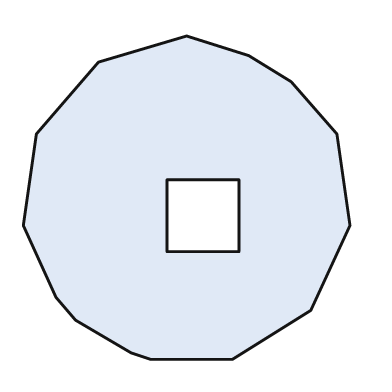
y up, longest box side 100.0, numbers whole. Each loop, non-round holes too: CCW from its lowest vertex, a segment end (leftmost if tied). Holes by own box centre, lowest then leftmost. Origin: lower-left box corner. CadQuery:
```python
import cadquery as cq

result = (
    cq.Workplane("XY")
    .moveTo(39.0, 0.0)
    .lineTo(64.0, 0.0)
    .lineTo(88.0, 15.0)
    .lineTo(100.0, 41.0)
    .lineTo(96.0, 69.0)
    .lineTo(82.0, 85.0)
    .lineTo(69.0, 93.0)
    .lineTo(50.0, 99.0)
    .lineTo(23.0, 91.0)
    .lineTo(4.0, 69.0)
    .lineTo(0.0, 41.0)
    .lineTo(10.0, 19.0)
    .lineTo(16.0, 12.0)
    .lineTo(33.0, 2.0)
    .close()
    .moveTo(44.0, 33.0)
    .lineTo(66.0, 33.0)
    .lineTo(66.0, 55.0)
    .lineTo(44.0, 55.0)
    .close()
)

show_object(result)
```